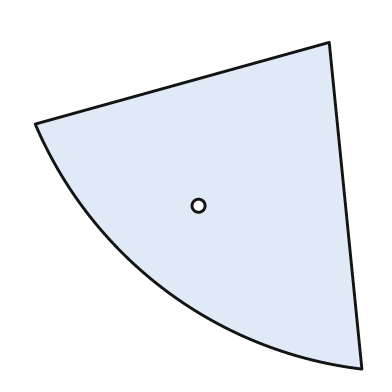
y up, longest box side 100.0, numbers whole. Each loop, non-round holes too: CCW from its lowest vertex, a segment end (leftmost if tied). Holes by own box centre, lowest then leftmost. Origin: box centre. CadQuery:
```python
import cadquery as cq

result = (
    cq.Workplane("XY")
    .moveTo(50.0, -50.0)
    .lineTo(40.0, 50.0)
    .lineTo(-50.0, 25.0)
    .threePointArc((-10.0, -26.0), (50.0, -50.0))
    .close()
    .moveTo(0.0, 0.0)
    .circle(2.0)
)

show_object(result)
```